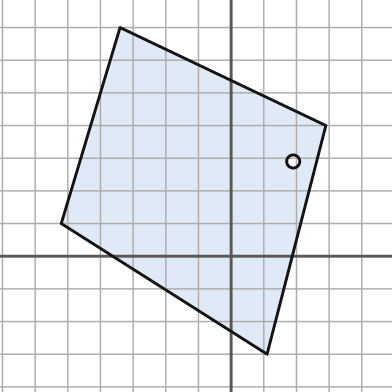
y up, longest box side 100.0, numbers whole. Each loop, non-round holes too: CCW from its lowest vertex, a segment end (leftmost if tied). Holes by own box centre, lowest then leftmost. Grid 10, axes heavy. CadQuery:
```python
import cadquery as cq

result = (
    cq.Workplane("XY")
    .moveTo(11.0, -30.0)
    .lineTo(29.0, 40.0)
    .lineTo(-34.0, 70.0)
    .lineTo(-52.0, 10.0)
    .close()
    .moveTo(19.0, 29.0)
    .circle(2.0)
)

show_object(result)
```